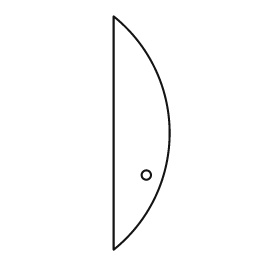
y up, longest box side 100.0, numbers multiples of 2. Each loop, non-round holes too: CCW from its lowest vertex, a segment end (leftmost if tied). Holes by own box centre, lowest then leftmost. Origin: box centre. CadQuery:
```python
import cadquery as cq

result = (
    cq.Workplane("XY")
    .moveTo(-12.0, -50.0)
    .threePointArc((12.0, 0.0), (-12.0, 50.0))
    .close()
    .moveTo(2.0, -18.0)
    .circle(2.0)
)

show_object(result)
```